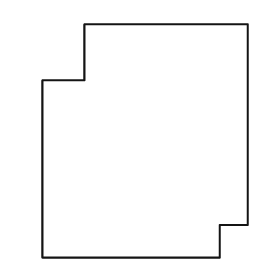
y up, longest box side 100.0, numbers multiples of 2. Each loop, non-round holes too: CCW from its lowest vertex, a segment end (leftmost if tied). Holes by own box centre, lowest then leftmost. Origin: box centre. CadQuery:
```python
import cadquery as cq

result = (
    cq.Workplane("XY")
    .moveTo(-44.0, -50.0)
    .lineTo(32.0, -50.0)
    .lineTo(32.0, -36.0)
    .lineTo(44.0, -36.0)
    .lineTo(44.0, 50.0)
    .lineTo(-26.0, 50.0)
    .lineTo(-26.0, 26.0)
    .lineTo(-44.0, 26.0)
    .close()
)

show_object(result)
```